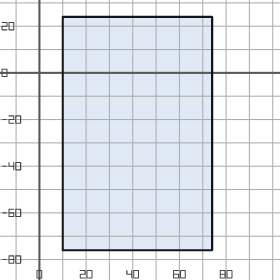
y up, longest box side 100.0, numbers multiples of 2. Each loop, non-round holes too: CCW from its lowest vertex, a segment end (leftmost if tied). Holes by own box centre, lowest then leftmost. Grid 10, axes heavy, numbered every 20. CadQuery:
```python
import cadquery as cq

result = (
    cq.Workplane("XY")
    .moveTo(10.0, -76.0)
    .lineTo(74.0, -76.0)
    .lineTo(74.0, 24.0)
    .lineTo(10.0, 24.0)
    .close()
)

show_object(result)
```